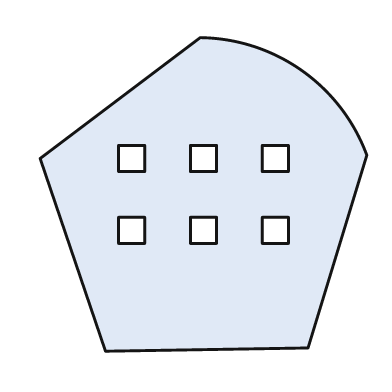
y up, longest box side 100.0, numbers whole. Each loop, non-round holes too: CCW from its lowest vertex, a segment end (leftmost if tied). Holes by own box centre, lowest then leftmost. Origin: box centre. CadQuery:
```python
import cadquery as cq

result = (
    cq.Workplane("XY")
    .moveTo(-30.0, -48.0)
    .lineTo(32.0, -47.0)
    .lineTo(50.0, 12.0)
    .threePointArc((30.0, 38.0), (-1.0, 48.0))
    .lineTo(-50.0, 11.0)
    .close()
    .moveTo(-26.0, -15.0)
    .lineTo(-18.0, -15.0)
    .lineTo(-18.0, -7.0)
    .lineTo(-26.0, -7.0)
    .close()
    .moveTo(-4.0, -15.0)
    .lineTo(4.0, -15.0)
    .lineTo(4.0, -7.0)
    .lineTo(-4.0, -7.0)
    .close()
    .moveTo(18.0, -15.0)
    .lineTo(26.0, -15.0)
    .lineTo(26.0, -7.0)
    .lineTo(18.0, -7.0)
    .close()
    .moveTo(-26.0, 7.0)
    .lineTo(-18.0, 7.0)
    .lineTo(-18.0, 15.0)
    .lineTo(-26.0, 15.0)
    .close()
    .moveTo(-4.0, 7.0)
    .lineTo(4.0, 7.0)
    .lineTo(4.0, 15.0)
    .lineTo(-4.0, 15.0)
    .close()
    .moveTo(18.0, 7.0)
    .lineTo(26.0, 7.0)
    .lineTo(26.0, 15.0)
    .lineTo(18.0, 15.0)
    .close()
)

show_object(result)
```